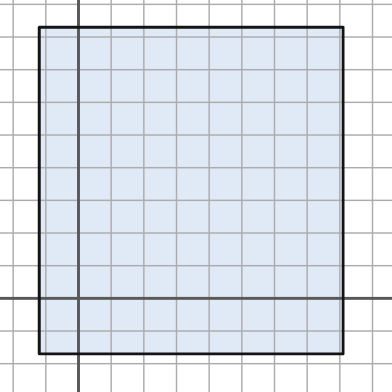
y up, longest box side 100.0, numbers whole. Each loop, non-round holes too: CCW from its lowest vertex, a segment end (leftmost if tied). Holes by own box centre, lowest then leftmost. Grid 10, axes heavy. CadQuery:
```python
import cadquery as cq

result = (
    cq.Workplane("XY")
    .moveTo(-12.0, -17.0)
    .lineTo(81.0, -17.0)
    .lineTo(81.0, 83.0)
    .lineTo(-12.0, 83.0)
    .close()
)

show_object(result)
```